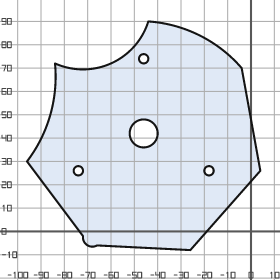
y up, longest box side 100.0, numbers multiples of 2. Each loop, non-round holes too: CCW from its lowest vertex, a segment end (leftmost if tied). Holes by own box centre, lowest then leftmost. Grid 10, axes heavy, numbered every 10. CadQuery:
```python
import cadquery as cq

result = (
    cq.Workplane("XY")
    .moveTo(-26.0, -8.0)
    .lineTo(4.0, 26.0)
    .lineTo(-4.0, 70.0)
    .threePointArc((-22.0, 84.0), (-44.0, 90.0))
    .threePointArc((-60.0, 72.0), (-84.0, 72.0))
    .threePointArc((-86.0, 50.0), (-96.0, 30.0))
    .lineTo(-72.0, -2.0)
    .threePointArc((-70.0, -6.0), (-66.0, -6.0))
    .close()
    .moveTo(-74.0, 26.0)
    .circle(2.0)
    .moveTo(-18.0, 26.0)
    .circle(2.0)
    .moveTo(-46.0, 42.0)
    .circle(6.0)
    .moveTo(-46.0, 74.0)
    .circle(2.0)
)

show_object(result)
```